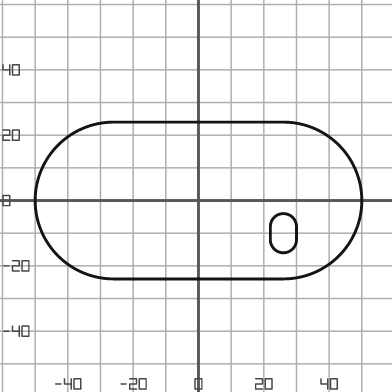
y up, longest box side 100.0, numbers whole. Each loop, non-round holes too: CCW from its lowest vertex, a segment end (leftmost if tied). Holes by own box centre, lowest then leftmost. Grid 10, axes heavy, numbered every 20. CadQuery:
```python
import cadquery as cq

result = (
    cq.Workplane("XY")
    .moveTo(-26.0, -24.0)
    .lineTo(26.0, -24.0)
    .threePointArc((50.0, 0.0), (26.0, 24.0))
    .lineTo(-26.0, 24.0)
    .threePointArc((-50.0, 0.0), (-26.0, -24.0))
    .close()
    .moveTo(22.0, -12.0)
    .threePointArc((26.0, -16.0), (30.0, -12.0))
    .lineTo(30.0, -8.0)
    .threePointArc((26.0, -4.0), (22.0, -8.0))
    .close()
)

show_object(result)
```